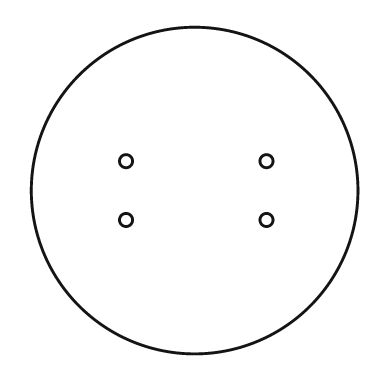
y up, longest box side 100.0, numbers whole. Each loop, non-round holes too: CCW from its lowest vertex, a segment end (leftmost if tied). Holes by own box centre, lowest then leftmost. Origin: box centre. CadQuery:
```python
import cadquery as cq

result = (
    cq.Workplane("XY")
    .moveTo(0.0, 0.0)
    .circle(50.0)
    .moveTo(-21.0, -9.0)
    .circle(2.0)
    .moveTo(22.0, -9.0)
    .circle(2.0)
    .moveTo(-21.0, 9.0)
    .circle(2.0)
    .moveTo(22.0, 9.0)
    .circle(2.0)
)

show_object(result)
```